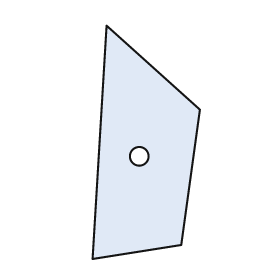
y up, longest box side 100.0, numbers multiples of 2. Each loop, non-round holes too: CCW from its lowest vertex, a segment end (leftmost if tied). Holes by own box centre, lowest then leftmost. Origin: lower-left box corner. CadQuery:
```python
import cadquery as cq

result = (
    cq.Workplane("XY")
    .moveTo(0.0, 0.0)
    .lineTo(38.0, 6.0)
    .lineTo(46.0, 64.0)
    .lineTo(6.0, 100.0)
    .close()
    .moveTo(20.0, 44.0)
    .circle(4.0)
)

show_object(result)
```